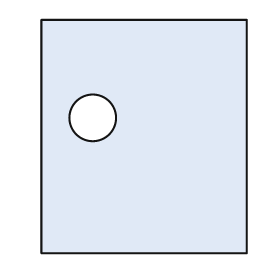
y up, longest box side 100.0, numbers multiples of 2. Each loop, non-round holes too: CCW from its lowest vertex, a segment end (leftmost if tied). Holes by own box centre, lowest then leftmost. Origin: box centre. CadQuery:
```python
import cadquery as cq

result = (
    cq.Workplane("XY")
    .moveTo(-44.0, -50.0)
    .lineTo(44.0, -50.0)
    .lineTo(44.0, 50.0)
    .lineTo(-44.0, 50.0)
    .close()
    .moveTo(-22.0, 8.0)
    .circle(10.0)
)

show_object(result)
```